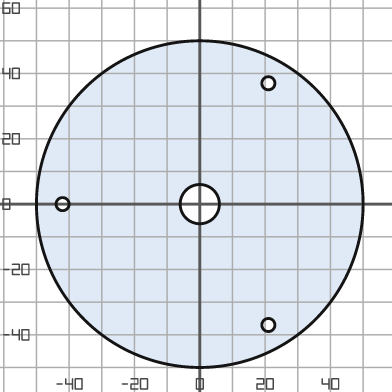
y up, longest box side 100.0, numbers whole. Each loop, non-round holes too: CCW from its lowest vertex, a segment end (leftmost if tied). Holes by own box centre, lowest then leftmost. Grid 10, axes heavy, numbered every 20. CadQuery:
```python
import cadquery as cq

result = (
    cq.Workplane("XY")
    .moveTo(0.0, 0.0)
    .circle(50.0)
    .moveTo(21.0, -37.0)
    .circle(2.0)
    .moveTo(-42.0, 0.0)
    .circle(2.0)
    .moveTo(0.0, 0.0)
    .circle(6.0)
    .moveTo(21.0, 37.0)
    .circle(2.0)
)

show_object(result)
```